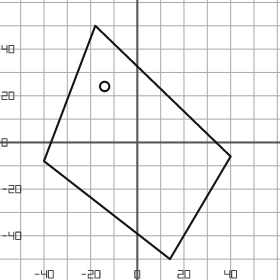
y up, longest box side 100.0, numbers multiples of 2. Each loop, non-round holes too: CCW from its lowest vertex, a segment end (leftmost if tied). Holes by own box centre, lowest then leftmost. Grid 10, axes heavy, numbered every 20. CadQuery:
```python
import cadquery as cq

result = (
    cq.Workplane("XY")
    .moveTo(14.0, -50.0)
    .lineTo(40.0, -6.0)
    .lineTo(-18.0, 50.0)
    .lineTo(-40.0, -8.0)
    .close()
    .moveTo(-14.0, 24.0)
    .circle(2.0)
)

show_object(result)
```